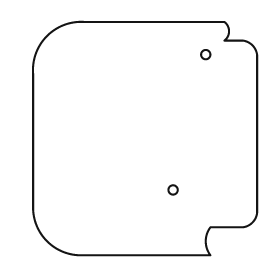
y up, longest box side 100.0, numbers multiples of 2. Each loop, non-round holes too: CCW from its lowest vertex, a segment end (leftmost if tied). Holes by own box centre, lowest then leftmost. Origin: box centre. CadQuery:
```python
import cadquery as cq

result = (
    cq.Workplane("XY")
    .moveTo(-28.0, -50.0)
    .lineTo(28.0, -50.0)
    .threePointArc((26.0, -44.0), (28.0, -38.0))
    .lineTo(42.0, -38.0)
    .threePointArc((46.0, -36.0), (48.0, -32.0))
    .lineTo(48.0, 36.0)
    .threePointArc((46.0, 40.0), (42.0, 42.0))
    .lineTo(34.0, 42.0)
    .threePointArc((36.0, 46.0), (34.0, 50.0))
    .lineTo(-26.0, 50.0)
    .threePointArc((-42.0, 44.0), (-48.0, 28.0))
    .lineTo(-48.0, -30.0)
    .threePointArc((-42.0, -44.0), (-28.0, -50.0))
    .close()
    .moveTo(12.0, -22.0)
    .circle(2.0)
    .moveTo(26.0, 36.0)
    .circle(2.0)
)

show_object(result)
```